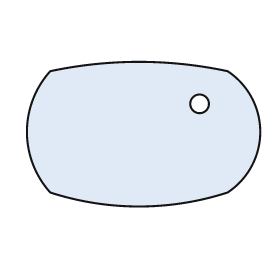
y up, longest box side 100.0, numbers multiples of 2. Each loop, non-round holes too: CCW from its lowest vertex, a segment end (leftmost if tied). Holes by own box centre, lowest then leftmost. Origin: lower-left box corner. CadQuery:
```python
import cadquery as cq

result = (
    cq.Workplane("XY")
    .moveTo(10.0, 6.0)
    .threePointArc((48.0, 0.0), (86.0, 6.0))
    .threePointArc((100.0, 32.0), (86.0, 58.0))
    .threePointArc((48.0, 62.0), (10.0, 58.0))
    .threePointArc((0.0, 32.0), (10.0, 6.0))
    .close()
    .moveTo(74.0, 44.0)
    .circle(4.0)
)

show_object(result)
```